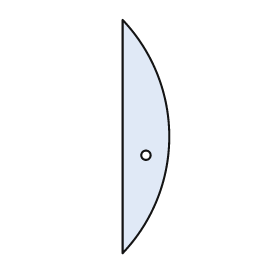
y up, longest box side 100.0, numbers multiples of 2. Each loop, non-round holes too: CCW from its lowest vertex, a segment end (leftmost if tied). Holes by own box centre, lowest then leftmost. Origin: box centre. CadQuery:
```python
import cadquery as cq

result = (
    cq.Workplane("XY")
    .moveTo(-10.0, -50.0)
    .threePointArc((10.0, 0.0), (-10.0, 50.0))
    .close()
    .moveTo(0.0, -8.0)
    .circle(2.0)
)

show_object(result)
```